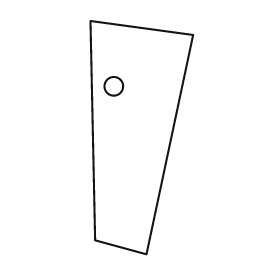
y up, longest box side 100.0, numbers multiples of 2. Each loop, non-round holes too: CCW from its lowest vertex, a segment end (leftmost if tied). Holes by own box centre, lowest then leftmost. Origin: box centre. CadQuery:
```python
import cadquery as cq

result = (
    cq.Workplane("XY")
    .moveTo(2.0, -50.0)
    .lineTo(22.0, 44.0)
    .lineTo(-22.0, 50.0)
    .lineTo(-20.0, -44.0)
    .close()
    .moveTo(-12.0, 22.0)
    .circle(4.0)
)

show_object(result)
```